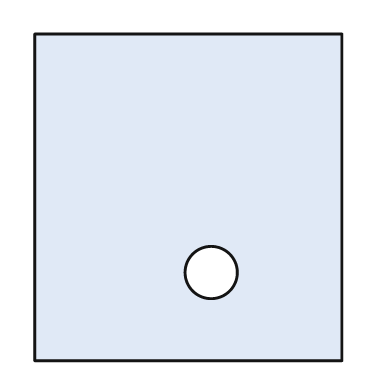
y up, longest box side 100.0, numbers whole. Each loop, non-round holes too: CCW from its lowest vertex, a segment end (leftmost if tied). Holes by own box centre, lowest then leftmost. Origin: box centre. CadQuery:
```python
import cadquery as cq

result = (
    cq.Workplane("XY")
    .moveTo(-47.0, -50.0)
    .lineTo(47.0, -50.0)
    .lineTo(47.0, 50.0)
    .lineTo(-47.0, 50.0)
    .close()
    .moveTo(7.0, -23.0)
    .circle(8.0)
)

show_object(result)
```